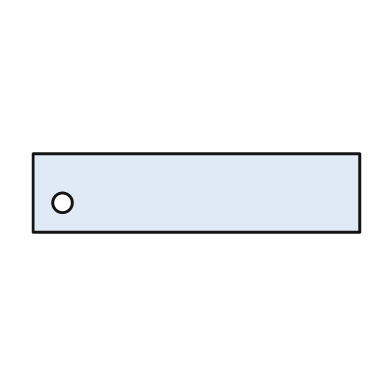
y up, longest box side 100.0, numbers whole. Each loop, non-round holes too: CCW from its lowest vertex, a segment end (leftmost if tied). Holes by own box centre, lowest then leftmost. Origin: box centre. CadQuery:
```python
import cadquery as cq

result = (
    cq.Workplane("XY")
    .moveTo(-50.0, -12.0)
    .lineTo(50.0, -12.0)
    .lineTo(50.0, 12.0)
    .lineTo(-50.0, 12.0)
    .close()
    .moveTo(-41.0, -3.0)
    .circle(3.0)
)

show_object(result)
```